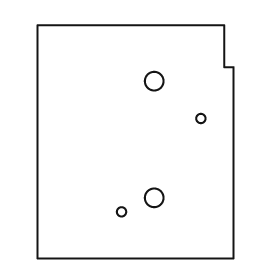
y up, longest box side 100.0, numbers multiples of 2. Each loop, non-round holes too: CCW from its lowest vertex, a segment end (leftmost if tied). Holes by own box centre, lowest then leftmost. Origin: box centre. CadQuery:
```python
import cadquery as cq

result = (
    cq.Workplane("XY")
    .moveTo(-42.0, -50.0)
    .lineTo(42.0, -50.0)
    .lineTo(42.0, 32.0)
    .lineTo(38.0, 32.0)
    .lineTo(38.0, 50.0)
    .lineTo(-42.0, 50.0)
    .close()
    .moveTo(-6.0, -30.0)
    .circle(2.0)
    .moveTo(8.0, -24.0)
    .circle(4.0)
    .moveTo(28.0, 10.0)
    .circle(2.0)
    .moveTo(8.0, 26.0)
    .circle(4.0)
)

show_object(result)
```